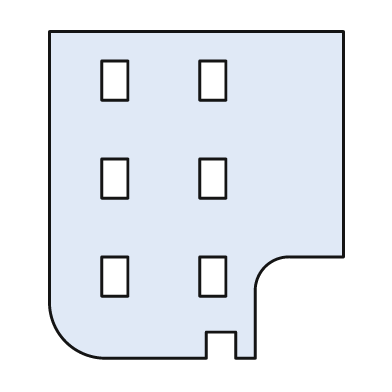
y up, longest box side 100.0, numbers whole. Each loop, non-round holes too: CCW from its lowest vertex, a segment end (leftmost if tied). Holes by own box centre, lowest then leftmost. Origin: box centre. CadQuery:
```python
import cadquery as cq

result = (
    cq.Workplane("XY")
    .moveTo(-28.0, -50.0)
    .lineTo(3.0, -50.0)
    .lineTo(3.0, -42.0)
    .lineTo(12.0, -42.0)
    .lineTo(12.0, -50.0)
    .lineTo(18.0, -50.0)
    .lineTo(18.0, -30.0)
    .threePointArc((21.0, -22.0), (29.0, -19.0))
    .lineTo(45.0, -19.0)
    .lineTo(45.0, 50.0)
    .lineTo(-45.0, 50.0)
    .lineTo(-45.0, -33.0)
    .threePointArc((-40.0, -45.0), (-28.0, -50.0))
    .close()
    .moveTo(-29.0, -31.0)
    .lineTo(-21.0, -31.0)
    .lineTo(-21.0, -19.0)
    .lineTo(-29.0, -19.0)
    .close()
    .moveTo(1.0, -31.0)
    .lineTo(9.0, -31.0)
    .lineTo(9.0, -19.0)
    .lineTo(1.0, -19.0)
    .close()
    .moveTo(-29.0, -1.0)
    .lineTo(-21.0, -1.0)
    .lineTo(-21.0, 11.0)
    .lineTo(-29.0, 11.0)
    .close()
    .moveTo(1.0, -1.0)
    .lineTo(9.0, -1.0)
    .lineTo(9.0, 11.0)
    .lineTo(1.0, 11.0)
    .close()
    .moveTo(-29.0, 29.0)
    .lineTo(-21.0, 29.0)
    .lineTo(-21.0, 41.0)
    .lineTo(-29.0, 41.0)
    .close()
    .moveTo(1.0, 29.0)
    .lineTo(9.0, 29.0)
    .lineTo(9.0, 41.0)
    .lineTo(1.0, 41.0)
    .close()
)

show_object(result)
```